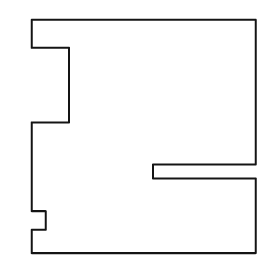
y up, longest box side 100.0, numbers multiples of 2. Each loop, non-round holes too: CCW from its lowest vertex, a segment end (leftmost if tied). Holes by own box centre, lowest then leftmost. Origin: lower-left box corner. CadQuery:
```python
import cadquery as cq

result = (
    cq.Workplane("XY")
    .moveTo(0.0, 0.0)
    .lineTo(96.0, 0.0)
    .lineTo(96.0, 32.0)
    .lineTo(52.0, 32.0)
    .lineTo(52.0, 38.0)
    .lineTo(96.0, 38.0)
    .lineTo(96.0, 100.0)
    .lineTo(0.0, 100.0)
    .lineTo(0.0, 88.0)
    .lineTo(16.0, 88.0)
    .lineTo(16.0, 56.0)
    .lineTo(0.0, 56.0)
    .lineTo(0.0, 18.0)
    .lineTo(6.0, 18.0)
    .lineTo(6.0, 10.0)
    .lineTo(0.0, 10.0)
    .close()
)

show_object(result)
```